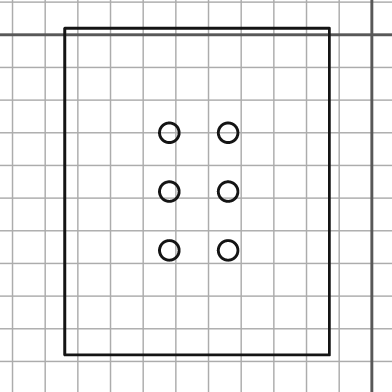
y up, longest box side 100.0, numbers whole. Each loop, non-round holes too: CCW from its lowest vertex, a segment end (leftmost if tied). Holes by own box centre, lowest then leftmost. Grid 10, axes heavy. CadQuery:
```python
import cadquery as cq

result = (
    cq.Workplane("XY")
    .moveTo(-94.0, -98.0)
    .lineTo(-13.0, -98.0)
    .lineTo(-13.0, 2.0)
    .lineTo(-94.0, 2.0)
    .close()
    .moveTo(-62.0, -66.0)
    .circle(3.0)
    .moveTo(-44.0, -66.0)
    .circle(3.0)
    .moveTo(-62.0, -48.0)
    .circle(3.0)
    .moveTo(-44.0, -48.0)
    .circle(3.0)
    .moveTo(-62.0, -30.0)
    .circle(3.0)
    .moveTo(-44.0, -30.0)
    .circle(3.0)
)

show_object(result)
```